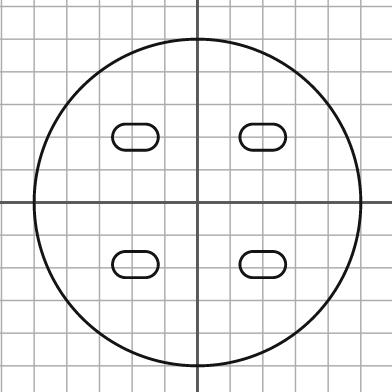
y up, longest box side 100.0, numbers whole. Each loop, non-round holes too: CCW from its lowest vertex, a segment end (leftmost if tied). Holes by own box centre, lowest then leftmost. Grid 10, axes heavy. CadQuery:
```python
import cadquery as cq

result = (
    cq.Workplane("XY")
    .moveTo(0.0, 0.0)
    .circle(50.0)
    .moveTo(-22.0, -23.0)
    .lineTo(-16.0, -23.0)
    .threePointArc((-12.0, -19.0), (-16.0, -15.0))
    .lineTo(-22.0, -15.0)
    .threePointArc((-26.0, -19.0), (-22.0, -23.0))
    .close()
    .moveTo(17.0, -23.0)
    .lineTo(23.0, -23.0)
    .threePointArc((27.0, -19.0), (23.0, -15.0))
    .lineTo(17.0, -15.0)
    .threePointArc((13.0, -19.0), (17.0, -23.0))
    .close()
    .moveTo(-22.0, 16.0)
    .lineTo(-16.0, 16.0)
    .threePointArc((-12.0, 20.0), (-16.0, 24.0))
    .lineTo(-22.0, 24.0)
    .threePointArc((-26.0, 20.0), (-22.0, 16.0))
    .close()
    .moveTo(17.0, 16.0)
    .lineTo(23.0, 16.0)
    .threePointArc((27.0, 20.0), (23.0, 24.0))
    .lineTo(17.0, 24.0)
    .threePointArc((13.0, 20.0), (17.0, 16.0))
    .close()
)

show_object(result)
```